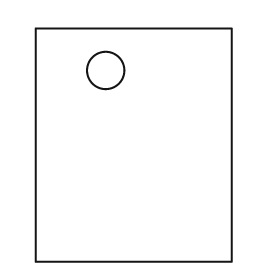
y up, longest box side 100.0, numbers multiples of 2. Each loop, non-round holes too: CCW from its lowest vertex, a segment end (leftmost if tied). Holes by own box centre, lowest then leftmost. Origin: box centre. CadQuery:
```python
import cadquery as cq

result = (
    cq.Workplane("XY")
    .moveTo(-42.0, -50.0)
    .lineTo(42.0, -50.0)
    .lineTo(42.0, 50.0)
    .lineTo(-42.0, 50.0)
    .close()
    .moveTo(-12.0, 32.0)
    .circle(8.0)
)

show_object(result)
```